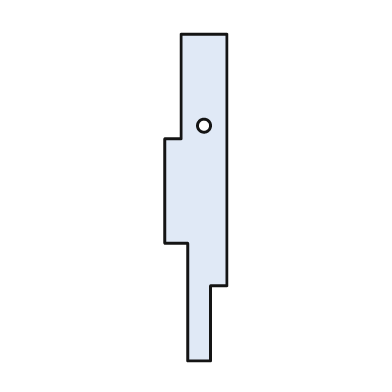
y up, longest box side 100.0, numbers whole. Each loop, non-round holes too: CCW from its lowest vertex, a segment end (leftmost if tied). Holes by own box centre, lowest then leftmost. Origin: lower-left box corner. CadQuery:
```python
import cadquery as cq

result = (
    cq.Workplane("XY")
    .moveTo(7.0, 0.0)
    .lineTo(14.0, 0.0)
    .lineTo(14.0, 23.0)
    .lineTo(19.0, 23.0)
    .lineTo(19.0, 100.0)
    .lineTo(5.0, 100.0)
    .lineTo(5.0, 68.0)
    .lineTo(0.0, 68.0)
    .lineTo(0.0, 36.0)
    .lineTo(7.0, 36.0)
    .close()
    .moveTo(12.0, 72.0)
    .circle(2.0)
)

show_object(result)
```